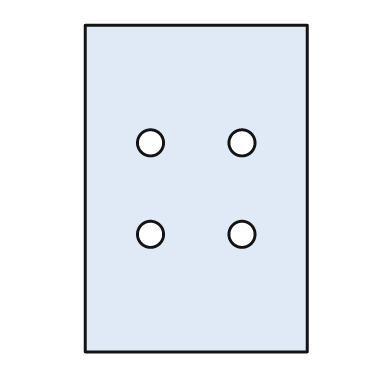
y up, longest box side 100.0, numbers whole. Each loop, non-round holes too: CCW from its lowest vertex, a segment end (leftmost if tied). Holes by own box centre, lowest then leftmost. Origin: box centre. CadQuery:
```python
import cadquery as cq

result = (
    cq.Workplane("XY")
    .moveTo(-34.0, -50.0)
    .lineTo(34.0, -50.0)
    .lineTo(34.0, 50.0)
    .lineTo(-34.0, 50.0)
    .close()
    .moveTo(-14.0, -14.0)
    .circle(4.0)
    .moveTo(14.0, -14.0)
    .circle(4.0)
    .moveTo(-14.0, 14.0)
    .circle(4.0)
    .moveTo(14.0, 14.0)
    .circle(4.0)
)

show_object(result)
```